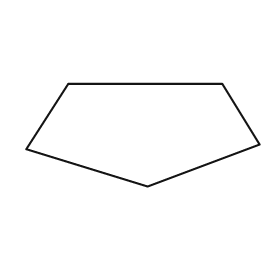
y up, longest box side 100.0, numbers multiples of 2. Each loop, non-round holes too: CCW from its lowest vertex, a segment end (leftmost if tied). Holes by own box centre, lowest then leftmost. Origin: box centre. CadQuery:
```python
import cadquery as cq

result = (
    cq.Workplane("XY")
    .moveTo(2.0, -22.0)
    .lineTo(50.0, -4.0)
    .lineTo(34.0, 22.0)
    .lineTo(-32.0, 22.0)
    .lineTo(-50.0, -6.0)
    .close()
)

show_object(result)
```